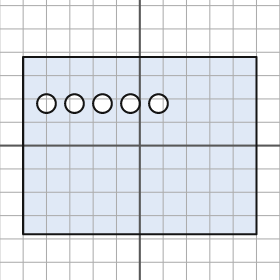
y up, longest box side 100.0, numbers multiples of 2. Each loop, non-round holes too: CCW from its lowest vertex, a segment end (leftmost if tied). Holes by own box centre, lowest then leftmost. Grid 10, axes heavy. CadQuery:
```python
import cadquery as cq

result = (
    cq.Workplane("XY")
    .moveTo(-50.0, -38.0)
    .lineTo(50.0, -38.0)
    .lineTo(50.0, 38.0)
    .lineTo(-50.0, 38.0)
    .close()
    .moveTo(-40.0, 18.0)
    .circle(4.0)
    .moveTo(-28.0, 18.0)
    .circle(4.0)
    .moveTo(-16.0, 18.0)
    .circle(4.0)
    .moveTo(-4.0, 18.0)
    .circle(4.0)
    .moveTo(8.0, 18.0)
    .circle(4.0)
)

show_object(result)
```